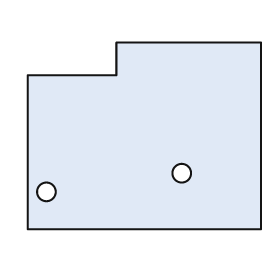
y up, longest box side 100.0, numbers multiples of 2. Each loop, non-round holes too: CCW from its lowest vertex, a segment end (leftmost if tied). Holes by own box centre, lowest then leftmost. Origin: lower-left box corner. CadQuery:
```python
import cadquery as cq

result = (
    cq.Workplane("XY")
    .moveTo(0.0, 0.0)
    .lineTo(100.0, 0.0)
    .lineTo(100.0, 80.0)
    .lineTo(38.0, 80.0)
    .lineTo(38.0, 66.0)
    .lineTo(0.0, 66.0)
    .close()
    .moveTo(8.0, 16.0)
    .circle(4.0)
    .moveTo(66.0, 24.0)
    .circle(4.0)
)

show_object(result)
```